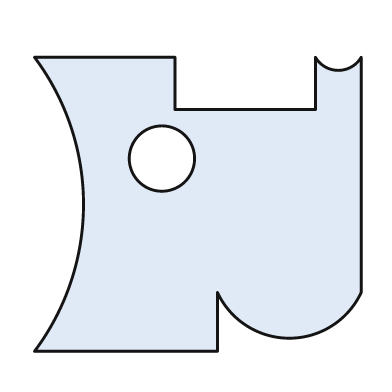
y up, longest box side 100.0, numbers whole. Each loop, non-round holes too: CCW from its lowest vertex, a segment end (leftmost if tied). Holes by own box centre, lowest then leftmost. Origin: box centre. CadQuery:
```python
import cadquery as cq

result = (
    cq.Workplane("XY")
    .moveTo(-50.0, -45.0)
    .lineTo(6.0, -45.0)
    .lineTo(6.0, -27.0)
    .threePointArc((28.0, -41.0), (50.0, -27.0))
    .lineTo(50.0, 45.0)
    .threePointArc((43.0, 41.0), (36.0, 45.0))
    .lineTo(36.0, 29.0)
    .lineTo(-7.0, 29.0)
    .lineTo(-7.0, 45.0)
    .lineTo(-50.0, 45.0)
    .threePointArc((-35.0, 0.0), (-50.0, -45.0))
    .close()
    .moveTo(-11.0, 14.0)
    .circle(10.0)
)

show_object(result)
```